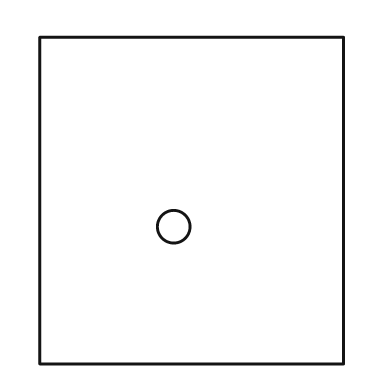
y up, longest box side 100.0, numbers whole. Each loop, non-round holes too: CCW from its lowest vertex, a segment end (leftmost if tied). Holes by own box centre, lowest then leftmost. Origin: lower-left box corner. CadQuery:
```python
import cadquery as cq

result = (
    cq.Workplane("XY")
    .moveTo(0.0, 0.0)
    .lineTo(93.0, 0.0)
    .lineTo(93.0, 100.0)
    .lineTo(0.0, 100.0)
    .close()
    .moveTo(41.0, 42.0)
    .circle(5.0)
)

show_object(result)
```